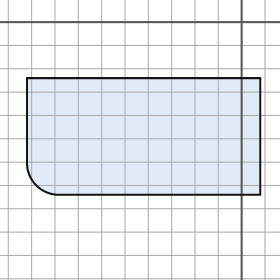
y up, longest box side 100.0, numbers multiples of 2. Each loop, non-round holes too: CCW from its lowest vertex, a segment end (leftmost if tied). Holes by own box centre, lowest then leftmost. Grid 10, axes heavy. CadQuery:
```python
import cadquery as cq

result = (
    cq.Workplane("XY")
    .moveTo(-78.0, -74.0)
    .lineTo(8.0, -74.0)
    .lineTo(8.0, -24.0)
    .lineTo(-92.0, -24.0)
    .lineTo(-92.0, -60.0)
    .threePointArc((-88.0, -70.0), (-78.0, -74.0))
    .close()
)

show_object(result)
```